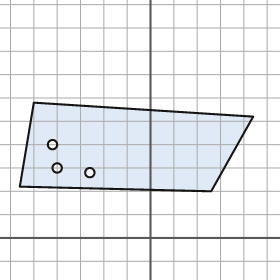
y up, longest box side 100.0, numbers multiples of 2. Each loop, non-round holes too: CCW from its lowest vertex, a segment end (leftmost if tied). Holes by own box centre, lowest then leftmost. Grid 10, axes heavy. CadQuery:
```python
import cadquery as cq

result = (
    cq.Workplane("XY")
    .moveTo(26.0, 20.0)
    .lineTo(44.0, 52.0)
    .lineTo(-50.0, 58.0)
    .lineTo(-56.0, 22.0)
    .close()
    .moveTo(-26.0, 28.0)
    .circle(2.0)
    .moveTo(-40.0, 30.0)
    .circle(2.0)
    .moveTo(-42.0, 40.0)
    .circle(2.0)
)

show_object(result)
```